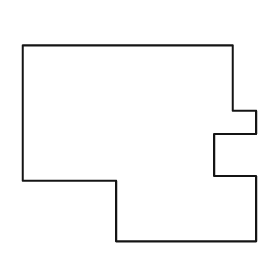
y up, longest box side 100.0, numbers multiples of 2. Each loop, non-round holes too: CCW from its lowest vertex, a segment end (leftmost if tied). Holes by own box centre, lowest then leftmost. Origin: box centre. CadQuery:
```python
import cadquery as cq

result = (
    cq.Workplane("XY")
    .moveTo(-10.0, -42.0)
    .lineTo(50.0, -42.0)
    .lineTo(50.0, -14.0)
    .lineTo(32.0, -14.0)
    .lineTo(32.0, 4.0)
    .lineTo(50.0, 4.0)
    .lineTo(50.0, 14.0)
    .lineTo(40.0, 14.0)
    .lineTo(40.0, 42.0)
    .lineTo(-50.0, 42.0)
    .lineTo(-50.0, -16.0)
    .lineTo(-10.0, -16.0)
    .close()
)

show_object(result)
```